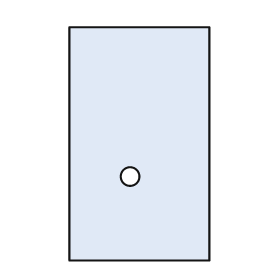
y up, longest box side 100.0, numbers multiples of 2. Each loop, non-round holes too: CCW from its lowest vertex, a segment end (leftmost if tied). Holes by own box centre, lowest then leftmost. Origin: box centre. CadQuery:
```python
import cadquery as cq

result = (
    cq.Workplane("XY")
    .moveTo(-30.0, -50.0)
    .lineTo(30.0, -50.0)
    .lineTo(30.0, 50.0)
    .lineTo(-30.0, 50.0)
    .close()
    .moveTo(-4.0, -14.0)
    .circle(4.0)
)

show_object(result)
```